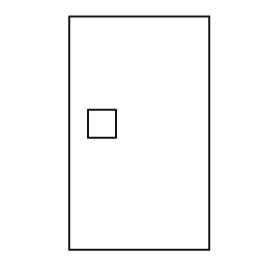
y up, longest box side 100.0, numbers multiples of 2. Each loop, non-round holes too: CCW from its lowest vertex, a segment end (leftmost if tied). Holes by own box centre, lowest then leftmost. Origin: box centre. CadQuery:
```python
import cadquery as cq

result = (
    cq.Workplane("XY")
    .moveTo(-30.0, -50.0)
    .lineTo(30.0, -50.0)
    .lineTo(30.0, 50.0)
    .lineTo(-30.0, 50.0)
    .close()
    .moveTo(-22.0, -2.0)
    .lineTo(-10.0, -2.0)
    .lineTo(-10.0, 10.0)
    .lineTo(-22.0, 10.0)
    .close()
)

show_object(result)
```